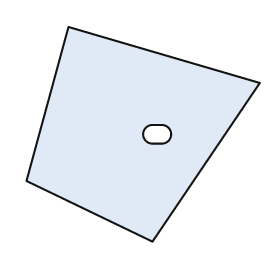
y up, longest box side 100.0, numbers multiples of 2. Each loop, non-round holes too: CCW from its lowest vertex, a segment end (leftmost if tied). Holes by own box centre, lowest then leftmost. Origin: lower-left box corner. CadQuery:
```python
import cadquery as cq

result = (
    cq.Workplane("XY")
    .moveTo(54.0, 0.0)
    .lineTo(100.0, 68.0)
    .lineTo(18.0, 92.0)
    .lineTo(0.0, 26.0)
    .close()
    .moveTo(54.0, 42.0)
    .lineTo(58.0, 42.0)
    .threePointArc((62.0, 46.0), (58.0, 50.0))
    .lineTo(54.0, 50.0)
    .threePointArc((50.0, 46.0), (54.0, 42.0))
    .close()
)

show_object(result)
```